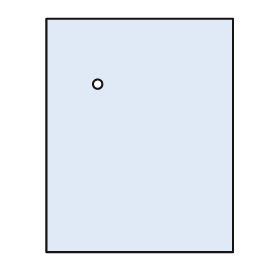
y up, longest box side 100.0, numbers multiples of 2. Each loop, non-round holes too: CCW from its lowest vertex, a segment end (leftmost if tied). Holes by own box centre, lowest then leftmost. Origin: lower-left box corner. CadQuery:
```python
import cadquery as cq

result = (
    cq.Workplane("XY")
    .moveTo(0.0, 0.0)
    .lineTo(80.0, 0.0)
    .lineTo(80.0, 100.0)
    .lineTo(0.0, 100.0)
    .close()
    .moveTo(22.0, 72.0)
    .circle(2.0)
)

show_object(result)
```